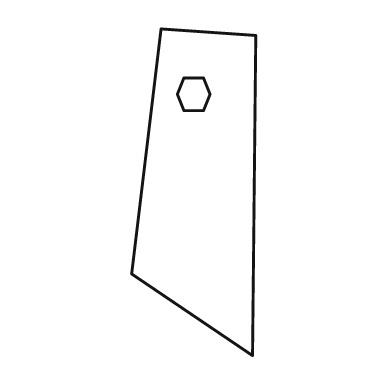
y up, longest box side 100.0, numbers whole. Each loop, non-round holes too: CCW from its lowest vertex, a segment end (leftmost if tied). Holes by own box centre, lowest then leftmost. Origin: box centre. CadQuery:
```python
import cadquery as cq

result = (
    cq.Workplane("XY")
    .moveTo(18.0, -50.0)
    .lineTo(19.0, 48.0)
    .lineTo(-10.0, 50.0)
    .lineTo(-19.0, -25.0)
    .close()
    .moveTo(-3.0, 25.0)
    .lineTo(3.0, 25.0)
    .lineTo(5.0, 30.0)
    .lineTo(3.0, 35.0)
    .lineTo(-3.0, 35.0)
    .lineTo(-5.0, 30.0)
    .close()
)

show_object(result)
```